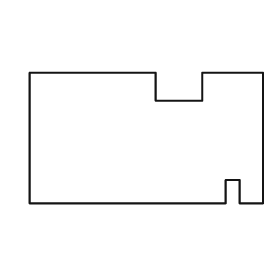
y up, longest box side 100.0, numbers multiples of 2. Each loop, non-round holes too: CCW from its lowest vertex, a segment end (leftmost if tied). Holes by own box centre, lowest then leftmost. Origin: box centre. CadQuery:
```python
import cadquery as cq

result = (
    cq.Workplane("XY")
    .moveTo(-50.0, -28.0)
    .lineTo(34.0, -28.0)
    .lineTo(34.0, -18.0)
    .lineTo(40.0, -18.0)
    .lineTo(40.0, -28.0)
    .lineTo(50.0, -28.0)
    .lineTo(50.0, 28.0)
    .lineTo(24.0, 28.0)
    .lineTo(24.0, 16.0)
    .lineTo(4.0, 16.0)
    .lineTo(4.0, 28.0)
    .lineTo(-50.0, 28.0)
    .close()
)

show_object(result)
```